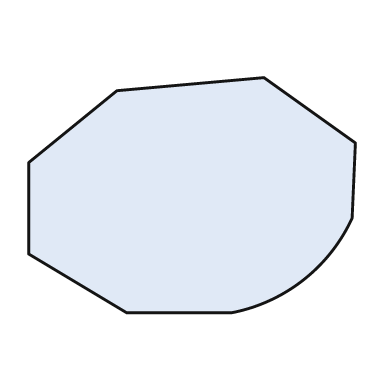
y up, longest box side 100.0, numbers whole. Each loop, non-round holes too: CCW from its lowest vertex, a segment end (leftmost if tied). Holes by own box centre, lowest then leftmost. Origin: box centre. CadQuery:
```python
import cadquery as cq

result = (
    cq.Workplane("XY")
    .moveTo(-20.0, -36.0)
    .lineTo(12.0, -36.0)
    .threePointArc((34.0, -26.0), (49.0, -7.0))
    .lineTo(50.0, 16.0)
    .lineTo(22.0, 36.0)
    .lineTo(-23.0, 32.0)
    .lineTo(-50.0, 10.0)
    .lineTo(-50.0, -18.0)
    .close()
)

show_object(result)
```